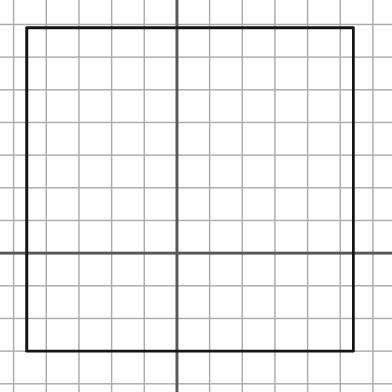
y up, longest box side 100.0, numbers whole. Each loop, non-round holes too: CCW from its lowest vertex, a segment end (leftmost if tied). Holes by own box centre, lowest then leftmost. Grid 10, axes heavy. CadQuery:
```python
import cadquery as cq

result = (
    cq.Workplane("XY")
    .moveTo(-46.0, -30.0)
    .lineTo(54.0, -30.0)
    .lineTo(54.0, 69.0)
    .lineTo(-46.0, 69.0)
    .close()
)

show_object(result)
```